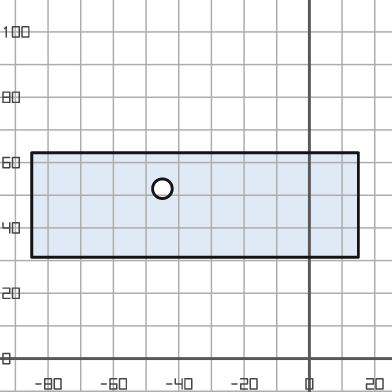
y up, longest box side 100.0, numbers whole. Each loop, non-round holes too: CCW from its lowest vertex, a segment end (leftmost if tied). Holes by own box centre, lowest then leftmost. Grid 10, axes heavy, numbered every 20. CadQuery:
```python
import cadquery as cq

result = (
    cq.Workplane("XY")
    .moveTo(-85.0, 31.0)
    .lineTo(15.0, 31.0)
    .lineTo(15.0, 63.0)
    .lineTo(-85.0, 63.0)
    .close()
    .moveTo(-45.0, 52.0)
    .circle(3.0)
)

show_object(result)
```